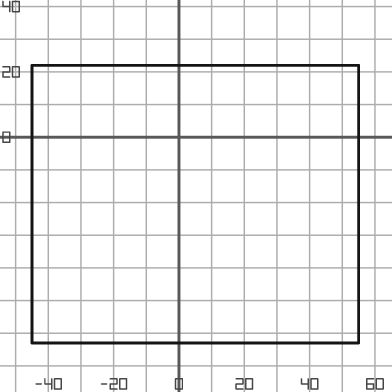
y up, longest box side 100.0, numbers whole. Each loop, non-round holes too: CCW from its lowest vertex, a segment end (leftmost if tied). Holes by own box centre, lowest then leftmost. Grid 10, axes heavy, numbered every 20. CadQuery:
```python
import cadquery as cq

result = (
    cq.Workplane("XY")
    .moveTo(-45.0, -63.0)
    .lineTo(55.0, -63.0)
    .lineTo(55.0, 22.0)
    .lineTo(-45.0, 22.0)
    .close()
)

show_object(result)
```